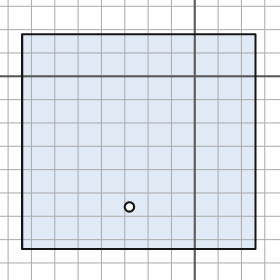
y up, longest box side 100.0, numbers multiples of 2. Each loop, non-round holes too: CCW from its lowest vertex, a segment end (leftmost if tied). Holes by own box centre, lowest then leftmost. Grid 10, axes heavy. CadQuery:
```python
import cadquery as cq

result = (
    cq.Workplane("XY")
    .moveTo(-74.0, -74.0)
    .lineTo(26.0, -74.0)
    .lineTo(26.0, 18.0)
    .lineTo(-74.0, 18.0)
    .close()
    .moveTo(-28.0, -56.0)
    .circle(2.0)
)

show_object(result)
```